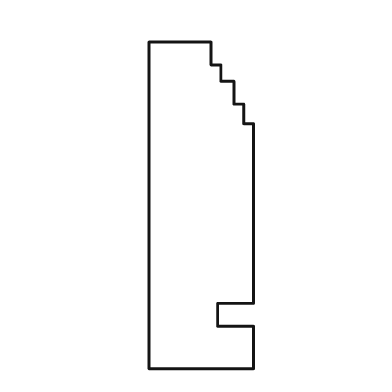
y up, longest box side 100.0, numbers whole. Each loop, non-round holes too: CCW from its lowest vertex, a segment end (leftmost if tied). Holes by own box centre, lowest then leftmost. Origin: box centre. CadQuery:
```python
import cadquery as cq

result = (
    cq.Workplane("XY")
    .moveTo(-16.0, -50.0)
    .lineTo(16.0, -50.0)
    .lineTo(16.0, -37.0)
    .lineTo(5.0, -37.0)
    .lineTo(5.0, -30.0)
    .lineTo(16.0, -30.0)
    .lineTo(16.0, 25.0)
    .lineTo(13.0, 25.0)
    .lineTo(13.0, 31.0)
    .lineTo(10.0, 31.0)
    .lineTo(10.0, 38.0)
    .lineTo(6.0, 38.0)
    .lineTo(6.0, 43.0)
    .lineTo(3.0, 43.0)
    .lineTo(3.0, 50.0)
    .lineTo(-16.0, 50.0)
    .close()
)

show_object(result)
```